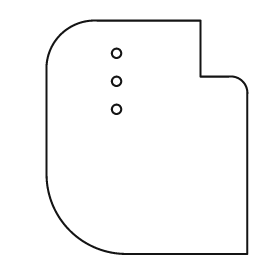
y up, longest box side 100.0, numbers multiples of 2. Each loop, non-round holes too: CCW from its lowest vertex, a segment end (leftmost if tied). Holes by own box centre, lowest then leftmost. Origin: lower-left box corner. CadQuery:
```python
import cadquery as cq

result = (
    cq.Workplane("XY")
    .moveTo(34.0, 0.0)
    .lineTo(86.0, 0.0)
    .lineTo(86.0, 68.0)
    .threePointArc((84.0, 74.0), (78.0, 76.0))
    .lineTo(66.0, 76.0)
    .lineTo(66.0, 100.0)
    .lineTo(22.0, 100.0)
    .threePointArc((6.0, 94.0), (0.0, 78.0))
    .lineTo(0.0, 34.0)
    .threePointArc((10.0, 10.0), (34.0, 0.0))
    .close()
    .moveTo(30.0, 62.0)
    .circle(2.0)
    .moveTo(30.0, 74.0)
    .circle(2.0)
    .moveTo(30.0, 86.0)
    .circle(2.0)
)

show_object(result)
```